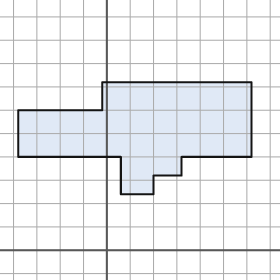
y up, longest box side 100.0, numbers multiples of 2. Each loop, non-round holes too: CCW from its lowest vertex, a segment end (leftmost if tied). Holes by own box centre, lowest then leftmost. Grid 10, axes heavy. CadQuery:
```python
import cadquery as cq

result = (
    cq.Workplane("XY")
    .moveTo(6.0, 24.0)
    .lineTo(20.0, 24.0)
    .lineTo(20.0, 32.0)
    .lineTo(32.0, 32.0)
    .lineTo(32.0, 40.0)
    .lineTo(62.0, 40.0)
    .lineTo(62.0, 72.0)
    .lineTo(-2.0, 72.0)
    .lineTo(-2.0, 60.0)
    .lineTo(-38.0, 60.0)
    .lineTo(-38.0, 40.0)
    .lineTo(6.0, 40.0)
    .close()
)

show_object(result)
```